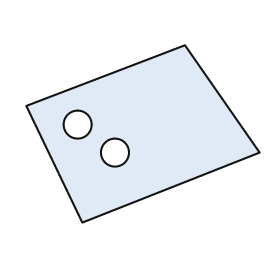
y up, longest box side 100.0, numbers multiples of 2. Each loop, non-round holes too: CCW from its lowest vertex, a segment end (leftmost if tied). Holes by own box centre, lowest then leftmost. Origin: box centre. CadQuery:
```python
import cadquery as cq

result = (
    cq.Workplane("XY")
    .moveTo(-26.0, -38.0)
    .lineTo(50.0, -8.0)
    .lineTo(18.0, 38.0)
    .lineTo(-50.0, 12.0)
    .close()
    .moveTo(-12.0, -8.0)
    .circle(6.0)
    .moveTo(-28.0, 4.0)
    .circle(6.0)
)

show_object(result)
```